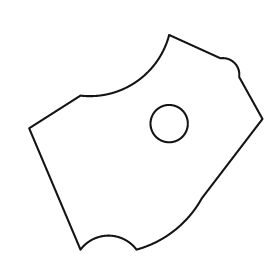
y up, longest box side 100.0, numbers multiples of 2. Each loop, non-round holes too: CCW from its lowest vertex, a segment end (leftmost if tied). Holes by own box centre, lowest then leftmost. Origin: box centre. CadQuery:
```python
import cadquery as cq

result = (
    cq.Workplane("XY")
    .moveTo(-28.0, -46.0)
    .threePointArc((-16.0, -40.0), (-4.0, -46.0))
    .threePointArc((12.0, -38.0), (24.0, -24.0))
    .lineTo(50.0, 10.0)
    .lineTo(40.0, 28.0)
    .threePointArc((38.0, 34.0), (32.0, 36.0))
    .lineTo(10.0, 46.0)
    .threePointArc((-4.0, 26.0), (-28.0, 20.0))
    .lineTo(-50.0, 6.0)
    .close()
    .moveTo(10.0, 8.0)
    .circle(8.0)
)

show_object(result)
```